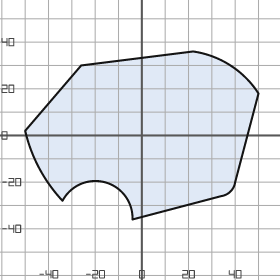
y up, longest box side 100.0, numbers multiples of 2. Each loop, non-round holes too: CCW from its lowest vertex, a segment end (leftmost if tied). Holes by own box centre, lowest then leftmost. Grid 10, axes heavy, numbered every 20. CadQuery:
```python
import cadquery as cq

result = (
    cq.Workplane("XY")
    .moveTo(-4.0, -36.0)
    .lineTo(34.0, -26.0)
    .threePointArc((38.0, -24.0), (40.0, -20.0))
    .lineTo(50.0, 18.0)
    .threePointArc((38.0, 30.0), (22.0, 36.0))
    .lineTo(-26.0, 30.0)
    .lineTo(-50.0, 2.0)
    .threePointArc((-44.0, -14.0), (-34.0, -28.0))
    .threePointArc((-16.0, -20.0), (-4.0, -36.0))
    .close()
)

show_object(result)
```